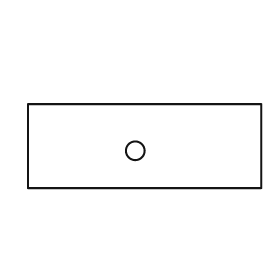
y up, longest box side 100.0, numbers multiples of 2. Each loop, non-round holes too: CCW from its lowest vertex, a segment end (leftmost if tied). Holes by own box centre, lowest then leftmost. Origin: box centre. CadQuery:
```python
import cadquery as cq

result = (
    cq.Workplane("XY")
    .moveTo(-50.0, -18.0)
    .lineTo(50.0, -18.0)
    .lineTo(50.0, 18.0)
    .lineTo(-50.0, 18.0)
    .close()
    .moveTo(-4.0, -2.0)
    .circle(4.0)
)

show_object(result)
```